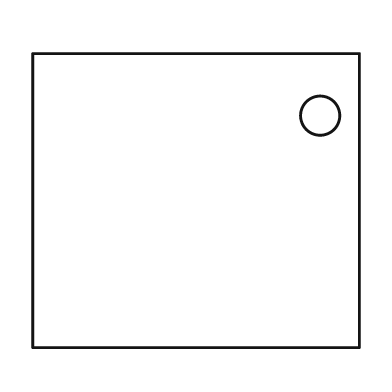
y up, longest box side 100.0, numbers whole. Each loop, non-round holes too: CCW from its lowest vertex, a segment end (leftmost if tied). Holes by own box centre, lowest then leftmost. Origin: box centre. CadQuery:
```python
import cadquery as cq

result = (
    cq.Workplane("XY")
    .moveTo(-50.0, -45.0)
    .lineTo(50.0, -45.0)
    .lineTo(50.0, 45.0)
    .lineTo(-50.0, 45.0)
    .close()
    .moveTo(38.0, 26.0)
    .circle(6.0)
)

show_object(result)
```